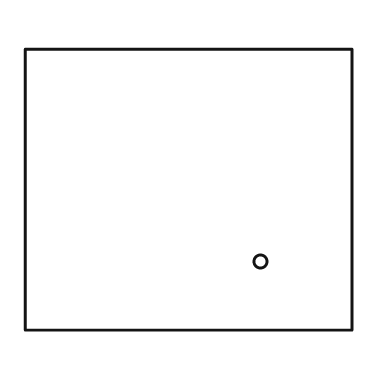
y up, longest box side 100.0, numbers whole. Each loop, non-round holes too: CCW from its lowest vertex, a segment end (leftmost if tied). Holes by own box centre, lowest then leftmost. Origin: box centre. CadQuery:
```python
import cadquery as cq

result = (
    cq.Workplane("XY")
    .moveTo(-50.0, -43.0)
    .lineTo(50.0, -43.0)
    .lineTo(50.0, 43.0)
    .lineTo(-50.0, 43.0)
    .close()
    .moveTo(22.0, -22.0)
    .circle(2.0)
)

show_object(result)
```